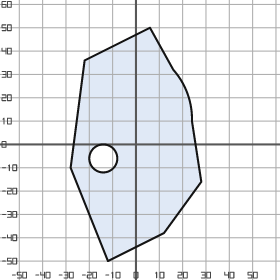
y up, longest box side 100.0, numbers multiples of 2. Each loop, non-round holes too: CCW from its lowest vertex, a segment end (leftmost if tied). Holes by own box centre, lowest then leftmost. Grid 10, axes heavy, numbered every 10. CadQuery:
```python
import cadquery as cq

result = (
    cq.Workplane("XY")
    .moveTo(-12.0, -50.0)
    .lineTo(12.0, -38.0)
    .lineTo(28.0, -16.0)
    .lineTo(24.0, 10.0)
    .threePointArc((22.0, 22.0), (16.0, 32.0))
    .lineTo(6.0, 50.0)
    .lineTo(-22.0, 36.0)
    .lineTo(-28.0, -10.0)
    .close()
    .moveTo(-14.0, -6.0)
    .circle(6.0)
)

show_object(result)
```